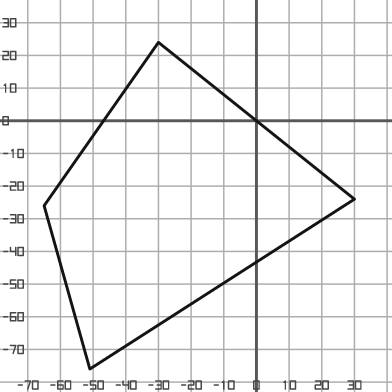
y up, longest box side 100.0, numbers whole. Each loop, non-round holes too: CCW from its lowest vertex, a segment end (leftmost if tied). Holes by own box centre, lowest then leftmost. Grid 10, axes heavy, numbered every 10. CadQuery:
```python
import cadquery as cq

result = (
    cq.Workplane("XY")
    .moveTo(-51.0, -76.0)
    .lineTo(30.0, -24.0)
    .lineTo(-30.0, 24.0)
    .lineTo(-65.0, -26.0)
    .close()
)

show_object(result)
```